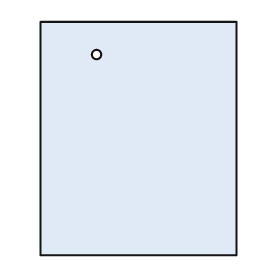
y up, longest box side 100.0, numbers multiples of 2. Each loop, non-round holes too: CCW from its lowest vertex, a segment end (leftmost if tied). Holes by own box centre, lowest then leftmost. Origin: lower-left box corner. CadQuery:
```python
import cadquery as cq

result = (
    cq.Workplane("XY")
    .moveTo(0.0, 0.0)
    .lineTo(84.0, 0.0)
    .lineTo(84.0, 100.0)
    .lineTo(0.0, 100.0)
    .close()
    .moveTo(24.0, 86.0)
    .circle(2.0)
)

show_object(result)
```